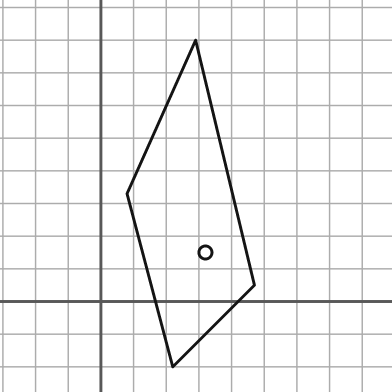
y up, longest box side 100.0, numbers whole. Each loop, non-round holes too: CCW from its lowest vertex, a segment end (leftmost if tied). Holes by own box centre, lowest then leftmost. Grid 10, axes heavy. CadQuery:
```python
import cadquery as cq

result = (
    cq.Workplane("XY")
    .moveTo(22.0, -20.0)
    .lineTo(47.0, 5.0)
    .lineTo(29.0, 80.0)
    .lineTo(8.0, 33.0)
    .close()
    .moveTo(32.0, 15.0)
    .circle(2.0)
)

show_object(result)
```